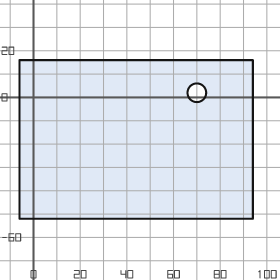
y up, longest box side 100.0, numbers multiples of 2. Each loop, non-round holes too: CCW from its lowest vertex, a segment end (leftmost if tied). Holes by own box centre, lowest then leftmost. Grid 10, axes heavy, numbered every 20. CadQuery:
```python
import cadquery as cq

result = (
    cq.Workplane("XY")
    .moveTo(-6.0, -52.0)
    .lineTo(94.0, -52.0)
    .lineTo(94.0, 16.0)
    .lineTo(-6.0, 16.0)
    .close()
    .moveTo(70.0, 2.0)
    .circle(4.0)
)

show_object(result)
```